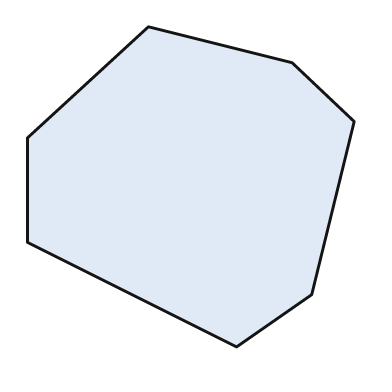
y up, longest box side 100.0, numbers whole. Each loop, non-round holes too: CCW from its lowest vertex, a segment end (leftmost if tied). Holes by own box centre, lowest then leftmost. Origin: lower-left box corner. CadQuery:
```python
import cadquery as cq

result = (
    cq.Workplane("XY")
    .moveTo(64.0, 0.0)
    .lineTo(87.0, 16.0)
    .lineTo(100.0, 69.0)
    .lineTo(81.0, 87.0)
    .lineTo(37.0, 98.0)
    .lineTo(0.0, 64.0)
    .lineTo(0.0, 32.0)
    .close()
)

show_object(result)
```